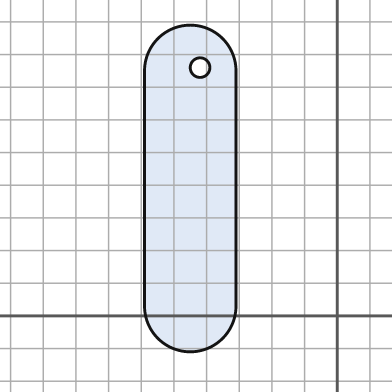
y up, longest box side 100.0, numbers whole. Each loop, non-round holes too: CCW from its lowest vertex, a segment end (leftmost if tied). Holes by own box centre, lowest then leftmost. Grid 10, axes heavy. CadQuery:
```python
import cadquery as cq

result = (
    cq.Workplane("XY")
    .moveTo(-59.0, 3.0)
    .threePointArc((-45.0, -11.0), (-31.0, 3.0))
    .lineTo(-31.0, 75.0)
    .threePointArc((-45.0, 89.0), (-59.0, 75.0))
    .close()
    .moveTo(-42.0, 76.0)
    .circle(3.0)
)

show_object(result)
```